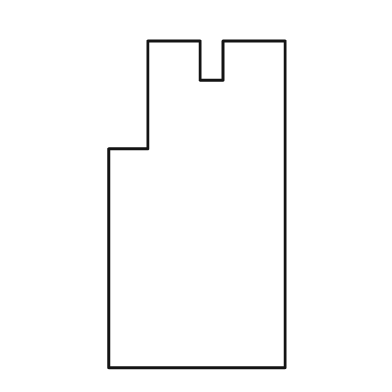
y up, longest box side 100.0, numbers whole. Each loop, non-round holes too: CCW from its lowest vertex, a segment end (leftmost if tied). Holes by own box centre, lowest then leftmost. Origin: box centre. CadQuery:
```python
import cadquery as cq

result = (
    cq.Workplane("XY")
    .moveTo(-27.0, -50.0)
    .lineTo(27.0, -50.0)
    .lineTo(27.0, 50.0)
    .lineTo(8.0, 50.0)
    .lineTo(8.0, 38.0)
    .lineTo(1.0, 38.0)
    .lineTo(1.0, 50.0)
    .lineTo(-15.0, 50.0)
    .lineTo(-15.0, 17.0)
    .lineTo(-27.0, 17.0)
    .close()
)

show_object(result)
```